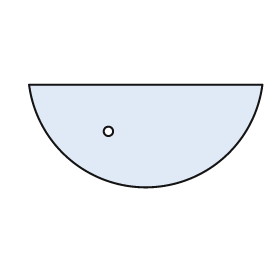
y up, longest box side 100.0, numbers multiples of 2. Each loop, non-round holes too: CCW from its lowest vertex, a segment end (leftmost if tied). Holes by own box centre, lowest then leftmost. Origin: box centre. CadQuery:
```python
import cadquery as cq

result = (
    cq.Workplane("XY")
    .moveTo(-50.0, 22.0)
    .threePointArc((0.0, -22.0), (50.0, 22.0))
    .close()
    .moveTo(-16.0, 2.0)
    .circle(2.0)
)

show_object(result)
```